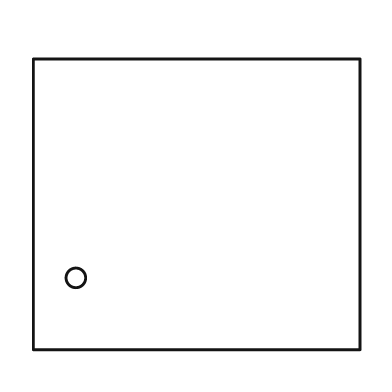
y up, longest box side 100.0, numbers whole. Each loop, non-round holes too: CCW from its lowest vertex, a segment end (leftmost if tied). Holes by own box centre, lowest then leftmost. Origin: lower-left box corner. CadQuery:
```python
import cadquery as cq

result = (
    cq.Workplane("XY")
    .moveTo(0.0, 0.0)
    .lineTo(100.0, 0.0)
    .lineTo(100.0, 89.0)
    .lineTo(0.0, 89.0)
    .close()
    .moveTo(13.0, 22.0)
    .circle(3.0)
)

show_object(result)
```